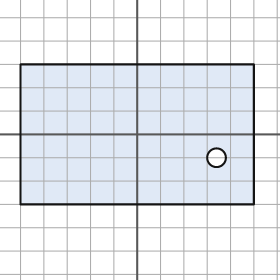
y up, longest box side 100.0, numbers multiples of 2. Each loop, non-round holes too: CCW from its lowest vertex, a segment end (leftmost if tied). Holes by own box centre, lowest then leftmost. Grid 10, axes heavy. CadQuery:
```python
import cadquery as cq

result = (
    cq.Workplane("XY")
    .moveTo(-50.0, -30.0)
    .lineTo(50.0, -30.0)
    .lineTo(50.0, 30.0)
    .lineTo(-50.0, 30.0)
    .close()
    .moveTo(34.0, -10.0)
    .circle(4.0)
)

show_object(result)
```